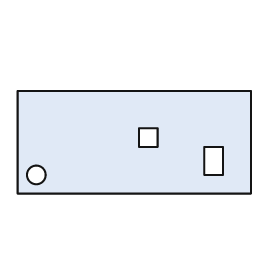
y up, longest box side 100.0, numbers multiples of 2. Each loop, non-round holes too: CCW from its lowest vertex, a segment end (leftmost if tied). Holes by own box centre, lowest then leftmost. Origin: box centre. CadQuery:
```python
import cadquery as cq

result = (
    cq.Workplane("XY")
    .moveTo(-50.0, -22.0)
    .lineTo(50.0, -22.0)
    .lineTo(50.0, 22.0)
    .lineTo(-50.0, 22.0)
    .close()
    .moveTo(-42.0, -14.0)
    .circle(4.0)
    .moveTo(30.0, -14.0)
    .lineTo(38.0, -14.0)
    .lineTo(38.0, -2.0)
    .lineTo(30.0, -2.0)
    .close()
    .moveTo(2.0, -2.0)
    .lineTo(10.0, -2.0)
    .lineTo(10.0, 6.0)
    .lineTo(2.0, 6.0)
    .close()
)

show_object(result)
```